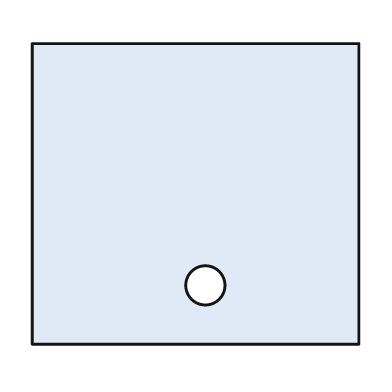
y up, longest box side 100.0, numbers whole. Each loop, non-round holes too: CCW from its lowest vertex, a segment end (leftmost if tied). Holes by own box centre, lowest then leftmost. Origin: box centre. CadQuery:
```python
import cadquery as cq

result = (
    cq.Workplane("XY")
    .moveTo(-50.0, -46.0)
    .lineTo(50.0, -46.0)
    .lineTo(50.0, 46.0)
    .lineTo(-50.0, 46.0)
    .close()
    .moveTo(3.0, -28.0)
    .circle(6.0)
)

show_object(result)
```